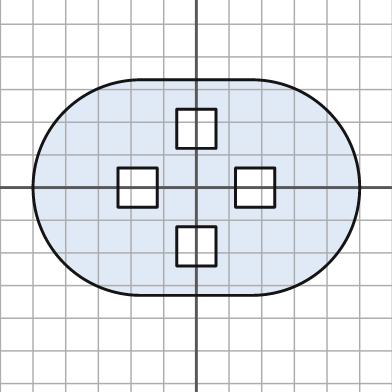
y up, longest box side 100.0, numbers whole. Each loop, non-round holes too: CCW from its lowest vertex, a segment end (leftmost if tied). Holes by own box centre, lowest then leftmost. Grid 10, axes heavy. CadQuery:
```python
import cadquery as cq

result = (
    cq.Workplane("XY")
    .moveTo(-17.0, -33.0)
    .lineTo(17.0, -33.0)
    .threePointArc((50.0, 0.0), (17.0, 33.0))
    .lineTo(-17.0, 33.0)
    .threePointArc((-50.0, 0.0), (-17.0, -33.0))
    .close()
    .moveTo(-6.0, -24.0)
    .lineTo(6.0, -24.0)
    .lineTo(6.0, -12.0)
    .lineTo(-6.0, -12.0)
    .close()
    .moveTo(-24.0, -6.0)
    .lineTo(-12.0, -6.0)
    .lineTo(-12.0, 6.0)
    .lineTo(-24.0, 6.0)
    .close()
    .moveTo(12.0, -6.0)
    .lineTo(24.0, -6.0)
    .lineTo(24.0, 6.0)
    .lineTo(12.0, 6.0)
    .close()
    .moveTo(-6.0, 12.0)
    .lineTo(6.0, 12.0)
    .lineTo(6.0, 24.0)
    .lineTo(-6.0, 24.0)
    .close()
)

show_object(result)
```